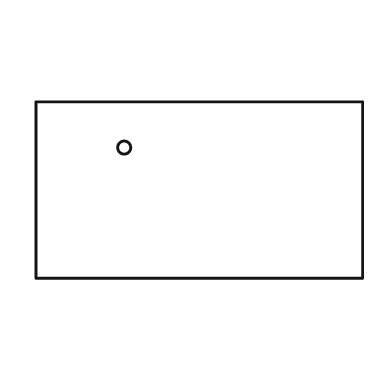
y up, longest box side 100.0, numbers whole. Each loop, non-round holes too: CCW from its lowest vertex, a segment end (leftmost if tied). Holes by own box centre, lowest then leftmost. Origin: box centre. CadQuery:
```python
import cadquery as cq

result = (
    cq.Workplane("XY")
    .moveTo(-50.0, -27.0)
    .lineTo(50.0, -27.0)
    .lineTo(50.0, 27.0)
    .lineTo(-50.0, 27.0)
    .close()
    .moveTo(-23.0, 13.0)
    .circle(2.0)
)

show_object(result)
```